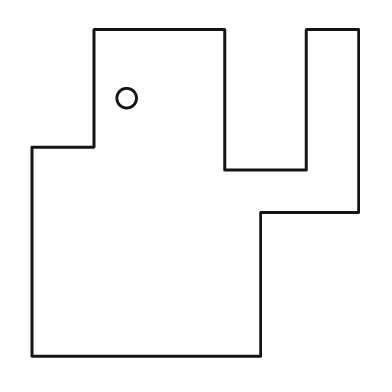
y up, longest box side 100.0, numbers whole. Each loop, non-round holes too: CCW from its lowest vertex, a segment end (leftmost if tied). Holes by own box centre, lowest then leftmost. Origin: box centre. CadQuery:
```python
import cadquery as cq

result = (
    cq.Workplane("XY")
    .moveTo(-50.0, -50.0)
    .lineTo(20.0, -50.0)
    .lineTo(20.0, -6.0)
    .lineTo(50.0, -6.0)
    .lineTo(50.0, 50.0)
    .lineTo(34.0, 50.0)
    .lineTo(34.0, 7.0)
    .lineTo(9.0, 7.0)
    .lineTo(9.0, 50.0)
    .lineTo(-31.0, 50.0)
    .lineTo(-31.0, 14.0)
    .lineTo(-50.0, 14.0)
    .close()
    .moveTo(-21.0, 29.0)
    .circle(3.0)
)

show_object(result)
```